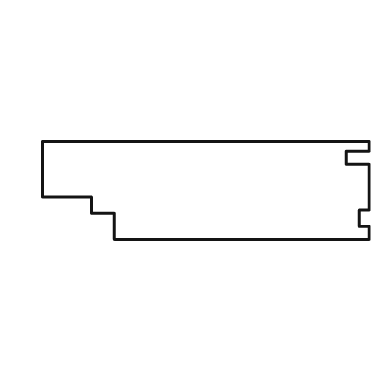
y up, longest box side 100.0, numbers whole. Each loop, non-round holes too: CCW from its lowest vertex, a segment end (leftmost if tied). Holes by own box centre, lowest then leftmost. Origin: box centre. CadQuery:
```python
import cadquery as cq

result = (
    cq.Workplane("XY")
    .moveTo(-28.0, -15.0)
    .lineTo(50.0, -15.0)
    .lineTo(50.0, -11.0)
    .lineTo(47.0, -11.0)
    .lineTo(47.0, -6.0)
    .lineTo(50.0, -6.0)
    .lineTo(50.0, 8.0)
    .lineTo(43.0, 8.0)
    .lineTo(43.0, 12.0)
    .lineTo(50.0, 12.0)
    .lineTo(50.0, 15.0)
    .lineTo(-50.0, 15.0)
    .lineTo(-50.0, -2.0)
    .lineTo(-35.0, -2.0)
    .lineTo(-35.0, -7.0)
    .lineTo(-28.0, -7.0)
    .close()
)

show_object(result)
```